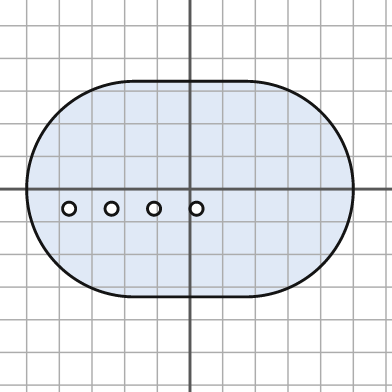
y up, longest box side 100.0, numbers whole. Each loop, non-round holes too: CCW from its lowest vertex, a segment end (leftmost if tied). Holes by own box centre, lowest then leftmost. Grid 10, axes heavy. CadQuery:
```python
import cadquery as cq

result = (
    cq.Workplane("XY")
    .moveTo(-17.0, -33.0)
    .lineTo(17.0, -33.0)
    .threePointArc((50.0, 0.0), (17.0, 33.0))
    .lineTo(-17.0, 33.0)
    .threePointArc((-50.0, 0.0), (-17.0, -33.0))
    .close()
    .moveTo(-37.0, -6.0)
    .circle(2.0)
    .moveTo(-24.0, -6.0)
    .circle(2.0)
    .moveTo(-11.0, -6.0)
    .circle(2.0)
    .moveTo(2.0, -6.0)
    .circle(2.0)
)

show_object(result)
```